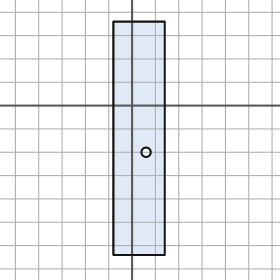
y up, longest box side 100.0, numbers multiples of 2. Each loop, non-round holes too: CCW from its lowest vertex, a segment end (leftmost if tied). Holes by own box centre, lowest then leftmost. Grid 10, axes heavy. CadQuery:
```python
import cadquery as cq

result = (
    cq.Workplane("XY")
    .moveTo(-8.0, -64.0)
    .lineTo(14.0, -64.0)
    .lineTo(14.0, 36.0)
    .lineTo(-8.0, 36.0)
    .close()
    .moveTo(6.0, -20.0)
    .circle(2.0)
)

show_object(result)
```